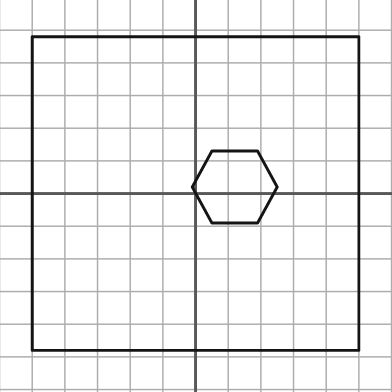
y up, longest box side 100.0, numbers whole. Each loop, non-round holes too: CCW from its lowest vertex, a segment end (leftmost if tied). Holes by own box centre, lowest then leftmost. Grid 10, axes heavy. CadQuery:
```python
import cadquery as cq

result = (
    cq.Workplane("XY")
    .moveTo(-50.0, -48.0)
    .lineTo(50.0, -48.0)
    .lineTo(50.0, 48.0)
    .lineTo(-50.0, 48.0)
    .close()
    .moveTo(5.0, -9.0)
    .lineTo(19.0, -9.0)
    .lineTo(25.0, 2.0)
    .lineTo(19.0, 13.0)
    .lineTo(5.0, 13.0)
    .lineTo(-1.0, 2.0)
    .close()
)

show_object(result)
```